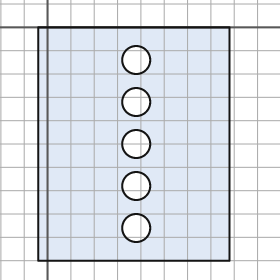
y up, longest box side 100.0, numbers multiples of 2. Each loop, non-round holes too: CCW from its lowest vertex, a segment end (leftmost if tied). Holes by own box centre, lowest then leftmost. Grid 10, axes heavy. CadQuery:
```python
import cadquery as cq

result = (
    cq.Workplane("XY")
    .moveTo(-4.0, -100.0)
    .lineTo(78.0, -100.0)
    .lineTo(78.0, 0.0)
    .lineTo(-4.0, 0.0)
    .close()
    .moveTo(38.0, -86.0)
    .circle(6.0)
    .moveTo(38.0, -68.0)
    .circle(6.0)
    .moveTo(38.0, -50.0)
    .circle(6.0)
    .moveTo(38.0, -32.0)
    .circle(6.0)
    .moveTo(38.0, -14.0)
    .circle(6.0)
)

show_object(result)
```